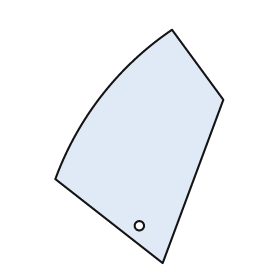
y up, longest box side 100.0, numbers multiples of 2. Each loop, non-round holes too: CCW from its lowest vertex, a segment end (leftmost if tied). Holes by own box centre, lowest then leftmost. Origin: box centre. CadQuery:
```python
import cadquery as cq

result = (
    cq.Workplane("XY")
    .moveTo(10.0, -50.0)
    .lineTo(36.0, 20.0)
    .lineTo(14.0, 50.0)
    .threePointArc((-16.0, 22.0), (-36.0, -14.0))
    .close()
    .moveTo(0.0, -34.0)
    .circle(2.0)
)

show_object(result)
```